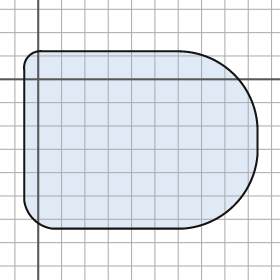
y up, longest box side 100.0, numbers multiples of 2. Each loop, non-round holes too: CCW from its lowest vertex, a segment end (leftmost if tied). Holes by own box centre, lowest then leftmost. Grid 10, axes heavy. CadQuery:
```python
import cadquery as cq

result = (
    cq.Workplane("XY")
    .moveTo(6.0, -64.0)
    .lineTo(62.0, -64.0)
    .threePointArc((84.0, -54.0), (94.0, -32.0))
    .lineTo(94.0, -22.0)
    .threePointArc((84.0, 2.0), (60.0, 12.0))
    .lineTo(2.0, 12.0)
    .threePointArc((-4.0, 10.0), (-6.0, 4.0))
    .lineTo(-6.0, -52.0)
    .threePointArc((-2.0, -60.0), (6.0, -64.0))
    .close()
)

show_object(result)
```